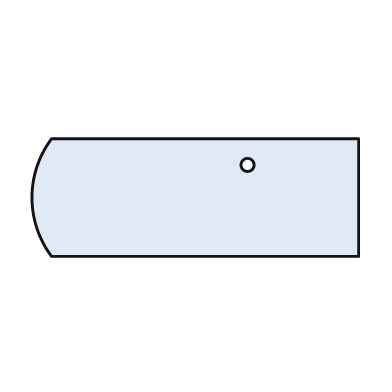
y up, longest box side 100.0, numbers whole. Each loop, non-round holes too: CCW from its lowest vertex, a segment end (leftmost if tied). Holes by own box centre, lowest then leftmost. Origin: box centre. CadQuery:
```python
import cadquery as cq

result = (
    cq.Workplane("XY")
    .moveTo(-44.0, -18.0)
    .lineTo(50.0, -18.0)
    .lineTo(50.0, 18.0)
    .lineTo(-44.0, 18.0)
    .threePointArc((-50.0, 0.0), (-44.0, -18.0))
    .close()
    .moveTo(16.0, 10.0)
    .circle(2.0)
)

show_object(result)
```